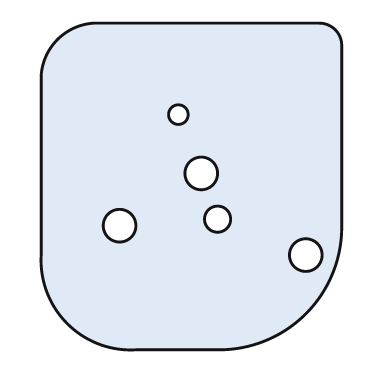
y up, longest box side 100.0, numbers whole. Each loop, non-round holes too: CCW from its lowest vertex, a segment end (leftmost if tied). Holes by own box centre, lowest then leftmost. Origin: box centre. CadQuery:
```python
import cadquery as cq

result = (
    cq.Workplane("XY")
    .moveTo(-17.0, -50.0)
    .lineTo(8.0, -50.0)
    .threePointArc((35.0, -39.0), (46.0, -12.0))
    .lineTo(46.0, 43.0)
    .threePointArc((44.0, 48.0), (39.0, 50.0))
    .lineTo(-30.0, 50.0)
    .threePointArc((-41.0, 45.0), (-46.0, 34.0))
    .lineTo(-46.0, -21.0)
    .threePointArc((-38.0, -42.0), (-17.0, -50.0))
    .close()
    .moveTo(35.0, -21.0)
    .circle(5.0)
    .moveTo(-22.0, -12.0)
    .circle(5.0)
    .moveTo(8.0, -10.0)
    .circle(4.0)
    .moveTo(3.0, 4.0)
    .circle(5.0)
    .moveTo(-4.0, 22.0)
    .circle(3.0)
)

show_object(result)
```